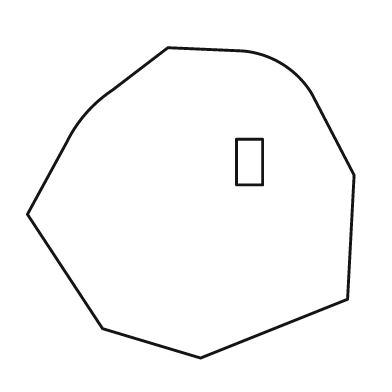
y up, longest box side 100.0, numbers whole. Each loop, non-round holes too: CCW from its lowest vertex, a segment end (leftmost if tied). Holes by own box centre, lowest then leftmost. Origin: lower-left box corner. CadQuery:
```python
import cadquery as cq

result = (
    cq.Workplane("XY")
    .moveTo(53.0, 0.0)
    .lineTo(98.0, 18.0)
    .lineTo(100.0, 56.0)
    .lineTo(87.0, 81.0)
    .threePointArc((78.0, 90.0), (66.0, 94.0))
    .lineTo(43.0, 95.0)
    .lineTo(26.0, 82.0)
    .threePointArc((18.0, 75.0), (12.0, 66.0))
    .lineTo(0.0, 44.0)
    .lineTo(23.0, 9.0)
    .close()
    .moveTo(64.0, 53.0)
    .lineTo(72.0, 53.0)
    .lineTo(72.0, 67.0)
    .lineTo(64.0, 67.0)
    .close()
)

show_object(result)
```